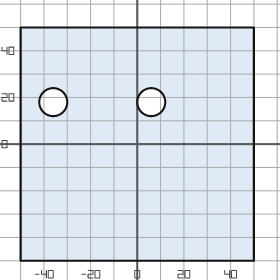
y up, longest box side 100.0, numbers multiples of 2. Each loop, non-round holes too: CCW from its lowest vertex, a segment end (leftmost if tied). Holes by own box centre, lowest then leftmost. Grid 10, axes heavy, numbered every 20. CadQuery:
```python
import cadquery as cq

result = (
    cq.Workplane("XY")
    .moveTo(-50.0, -50.0)
    .lineTo(50.0, -50.0)
    .lineTo(50.0, 50.0)
    .lineTo(-50.0, 50.0)
    .close()
    .moveTo(-36.0, 18.0)
    .circle(6.0)
    .moveTo(6.0, 18.0)
    .circle(6.0)
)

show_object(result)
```